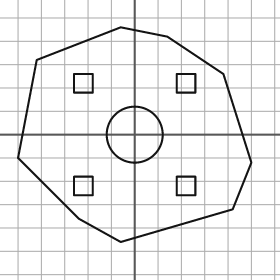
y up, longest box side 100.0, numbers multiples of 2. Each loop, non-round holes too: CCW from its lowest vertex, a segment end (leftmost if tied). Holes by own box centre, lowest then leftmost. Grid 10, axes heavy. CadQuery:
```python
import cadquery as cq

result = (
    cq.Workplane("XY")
    .moveTo(-6.0, -46.0)
    .lineTo(42.0, -32.0)
    .lineTo(50.0, -12.0)
    .lineTo(38.0, 26.0)
    .lineTo(14.0, 42.0)
    .lineTo(-6.0, 46.0)
    .lineTo(-42.0, 32.0)
    .lineTo(-50.0, -10.0)
    .lineTo(-24.0, -36.0)
    .close()
    .moveTo(-26.0, -26.0)
    .lineTo(-18.0, -26.0)
    .lineTo(-18.0, -18.0)
    .lineTo(-26.0, -18.0)
    .close()
    .moveTo(18.0, -26.0)
    .lineTo(26.0, -26.0)
    .lineTo(26.0, -18.0)
    .lineTo(18.0, -18.0)
    .close()
    .moveTo(0.0, 0.0)
    .circle(12.0)
    .moveTo(-26.0, 18.0)
    .lineTo(-18.0, 18.0)
    .lineTo(-18.0, 26.0)
    .lineTo(-26.0, 26.0)
    .close()
    .moveTo(18.0, 18.0)
    .lineTo(26.0, 18.0)
    .lineTo(26.0, 26.0)
    .lineTo(18.0, 26.0)
    .close()
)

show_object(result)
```